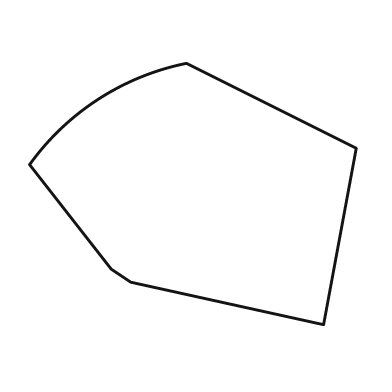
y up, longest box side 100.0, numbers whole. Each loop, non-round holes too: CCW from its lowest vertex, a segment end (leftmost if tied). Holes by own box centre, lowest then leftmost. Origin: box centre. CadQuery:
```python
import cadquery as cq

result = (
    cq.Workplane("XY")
    .moveTo(40.0, -40.0)
    .lineTo(50.0, 14.0)
    .lineTo(-2.0, 40.0)
    .threePointArc((-29.0, 29.0), (-50.0, 9.0))
    .lineTo(-25.0, -23.0)
    .lineTo(-19.0, -27.0)
    .close()
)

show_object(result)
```